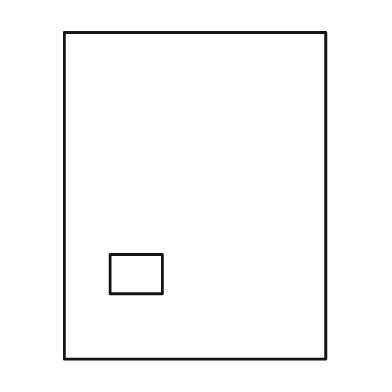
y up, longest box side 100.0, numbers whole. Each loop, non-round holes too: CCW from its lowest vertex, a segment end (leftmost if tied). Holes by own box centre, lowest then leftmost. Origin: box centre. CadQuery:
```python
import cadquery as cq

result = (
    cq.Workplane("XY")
    .moveTo(-40.0, -50.0)
    .lineTo(40.0, -50.0)
    .lineTo(40.0, 50.0)
    .lineTo(-40.0, 50.0)
    .close()
    .moveTo(-26.0, -30.0)
    .lineTo(-10.0, -30.0)
    .lineTo(-10.0, -18.0)
    .lineTo(-26.0, -18.0)
    .close()
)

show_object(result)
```